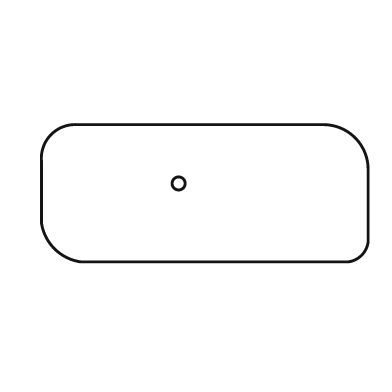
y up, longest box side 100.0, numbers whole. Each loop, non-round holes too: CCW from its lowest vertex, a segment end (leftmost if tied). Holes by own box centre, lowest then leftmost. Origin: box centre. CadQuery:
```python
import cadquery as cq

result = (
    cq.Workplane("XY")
    .moveTo(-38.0, -21.0)
    .lineTo(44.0, -21.0)
    .threePointArc((48.0, -19.0), (50.0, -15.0))
    .lineTo(50.0, 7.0)
    .threePointArc((46.0, 17.0), (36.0, 21.0))
    .lineTo(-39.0, 21.0)
    .threePointArc((-47.0, 18.0), (-50.0, 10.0))
    .lineTo(-50.0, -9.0)
    .threePointArc((-46.0, -17.0), (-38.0, -21.0))
    .close()
    .moveTo(-8.0, 3.0)
    .circle(2.0)
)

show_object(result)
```